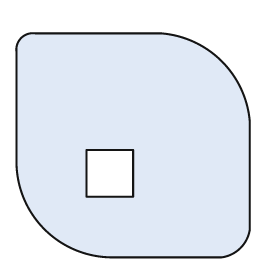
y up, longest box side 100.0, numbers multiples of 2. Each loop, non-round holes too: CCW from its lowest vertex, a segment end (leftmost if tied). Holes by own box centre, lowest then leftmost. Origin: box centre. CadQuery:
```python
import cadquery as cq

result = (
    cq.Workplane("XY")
    .moveTo(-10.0, -48.0)
    .lineTo(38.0, -48.0)
    .threePointArc((46.0, -44.0), (50.0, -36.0))
    .lineTo(50.0, 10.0)
    .threePointArc((38.0, 36.0), (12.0, 48.0))
    .lineTo(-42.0, 48.0)
    .threePointArc((-48.0, 46.0), (-50.0, 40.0))
    .lineTo(-50.0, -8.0)
    .threePointArc((-38.0, -36.0), (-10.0, -48.0))
    .close()
    .moveTo(-20.0, -22.0)
    .lineTo(0.0, -22.0)
    .lineTo(0.0, -2.0)
    .lineTo(-20.0, -2.0)
    .close()
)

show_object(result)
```